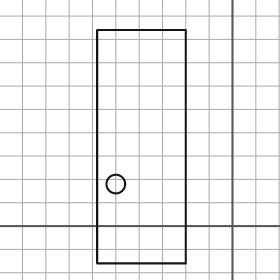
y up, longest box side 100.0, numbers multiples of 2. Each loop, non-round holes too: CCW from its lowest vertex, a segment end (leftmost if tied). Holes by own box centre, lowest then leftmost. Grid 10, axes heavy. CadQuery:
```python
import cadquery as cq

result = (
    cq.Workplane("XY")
    .moveTo(-58.0, -16.0)
    .lineTo(-20.0, -16.0)
    .lineTo(-20.0, 84.0)
    .lineTo(-58.0, 84.0)
    .close()
    .moveTo(-50.0, 18.0)
    .circle(4.0)
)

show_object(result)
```